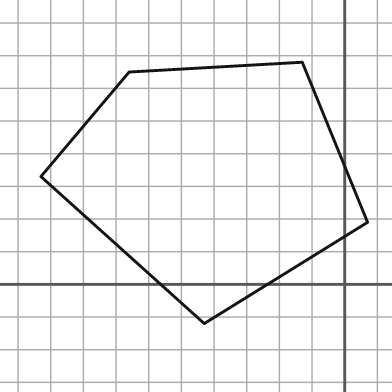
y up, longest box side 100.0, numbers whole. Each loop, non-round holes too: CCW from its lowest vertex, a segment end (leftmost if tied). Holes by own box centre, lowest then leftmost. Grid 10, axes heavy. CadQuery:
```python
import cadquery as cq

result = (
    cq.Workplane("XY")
    .moveTo(-43.0, -12.0)
    .lineTo(7.0, 19.0)
    .lineTo(-13.0, 68.0)
    .lineTo(-66.0, 65.0)
    .lineTo(-93.0, 33.0)
    .close()
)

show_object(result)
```